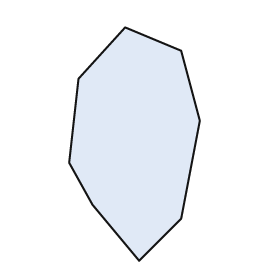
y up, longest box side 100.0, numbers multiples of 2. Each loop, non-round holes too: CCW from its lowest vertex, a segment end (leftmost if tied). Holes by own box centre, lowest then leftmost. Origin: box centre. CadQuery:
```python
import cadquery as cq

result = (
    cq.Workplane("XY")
    .moveTo(2.0, -50.0)
    .lineTo(20.0, -32.0)
    .lineTo(28.0, 10.0)
    .lineTo(20.0, 40.0)
    .lineTo(-4.0, 50.0)
    .lineTo(-24.0, 28.0)
    .lineTo(-28.0, -8.0)
    .lineTo(-18.0, -26.0)
    .close()
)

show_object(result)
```